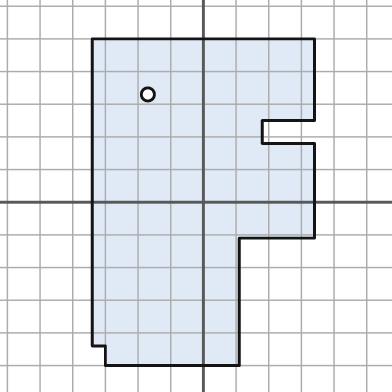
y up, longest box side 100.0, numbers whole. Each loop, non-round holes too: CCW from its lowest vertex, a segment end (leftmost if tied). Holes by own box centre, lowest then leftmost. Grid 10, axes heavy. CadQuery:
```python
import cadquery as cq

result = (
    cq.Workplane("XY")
    .moveTo(-30.0, -50.0)
    .lineTo(11.0, -50.0)
    .lineTo(11.0, -11.0)
    .lineTo(34.0, -11.0)
    .lineTo(34.0, 18.0)
    .lineTo(18.0, 18.0)
    .lineTo(18.0, 25.0)
    .lineTo(34.0, 25.0)
    .lineTo(34.0, 50.0)
    .lineTo(-34.0, 50.0)
    .lineTo(-34.0, -44.0)
    .lineTo(-30.0, -44.0)
    .close()
    .moveTo(-17.0, 33.0)
    .circle(2.0)
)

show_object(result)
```